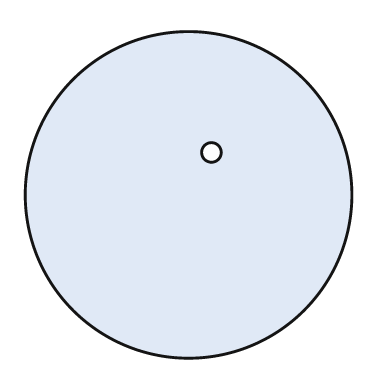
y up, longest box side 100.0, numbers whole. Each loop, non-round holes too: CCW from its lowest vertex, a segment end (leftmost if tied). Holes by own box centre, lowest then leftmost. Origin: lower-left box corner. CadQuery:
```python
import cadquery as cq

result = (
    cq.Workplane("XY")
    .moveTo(50.0, 50.0)
    .circle(50.0)
    .moveTo(57.0, 63.0)
    .circle(3.0)
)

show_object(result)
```